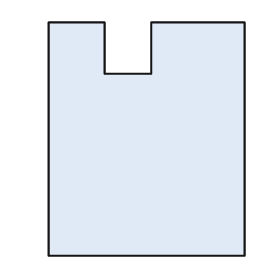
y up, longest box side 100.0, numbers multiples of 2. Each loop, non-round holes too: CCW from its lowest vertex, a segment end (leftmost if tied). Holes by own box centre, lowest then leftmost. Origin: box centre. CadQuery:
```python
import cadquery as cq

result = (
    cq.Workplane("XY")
    .moveTo(-42.0, -50.0)
    .lineTo(42.0, -50.0)
    .lineTo(42.0, 50.0)
    .lineTo(2.0, 50.0)
    .lineTo(2.0, 28.0)
    .lineTo(-18.0, 28.0)
    .lineTo(-18.0, 50.0)
    .lineTo(-42.0, 50.0)
    .close()
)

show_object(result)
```